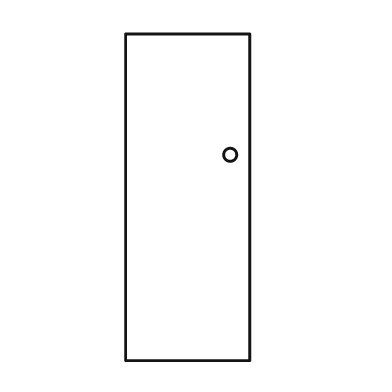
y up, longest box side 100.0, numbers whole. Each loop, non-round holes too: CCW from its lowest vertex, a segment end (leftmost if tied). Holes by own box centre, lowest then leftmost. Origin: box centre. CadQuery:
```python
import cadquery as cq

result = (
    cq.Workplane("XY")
    .moveTo(-19.0, -50.0)
    .lineTo(19.0, -50.0)
    .lineTo(19.0, 50.0)
    .lineTo(-19.0, 50.0)
    .close()
    .moveTo(13.0, 13.0)
    .circle(2.0)
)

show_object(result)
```